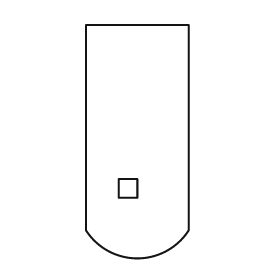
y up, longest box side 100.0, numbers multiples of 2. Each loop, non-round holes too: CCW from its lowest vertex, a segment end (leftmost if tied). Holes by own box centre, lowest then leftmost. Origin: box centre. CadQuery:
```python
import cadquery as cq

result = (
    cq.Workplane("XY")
    .moveTo(-22.0, -38.0)
    .threePointArc((0.0, -50.0), (22.0, -38.0))
    .lineTo(22.0, 50.0)
    .lineTo(-22.0, 50.0)
    .close()
    .moveTo(-8.0, -24.0)
    .lineTo(0.0, -24.0)
    .lineTo(0.0, -16.0)
    .lineTo(-8.0, -16.0)
    .close()
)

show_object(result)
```